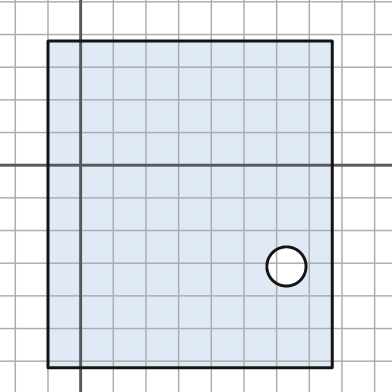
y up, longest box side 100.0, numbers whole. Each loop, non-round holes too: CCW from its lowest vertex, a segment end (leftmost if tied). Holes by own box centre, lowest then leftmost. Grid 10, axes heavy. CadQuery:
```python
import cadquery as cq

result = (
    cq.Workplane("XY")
    .moveTo(-10.0, -62.0)
    .lineTo(77.0, -62.0)
    .lineTo(77.0, 38.0)
    .lineTo(-10.0, 38.0)
    .close()
    .moveTo(63.0, -31.0)
    .circle(6.0)
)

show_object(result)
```